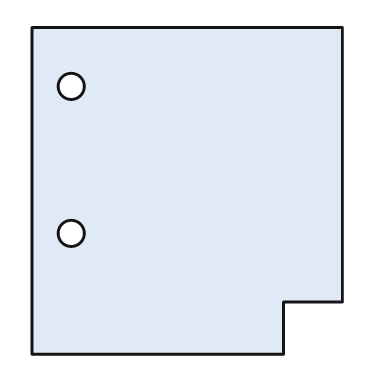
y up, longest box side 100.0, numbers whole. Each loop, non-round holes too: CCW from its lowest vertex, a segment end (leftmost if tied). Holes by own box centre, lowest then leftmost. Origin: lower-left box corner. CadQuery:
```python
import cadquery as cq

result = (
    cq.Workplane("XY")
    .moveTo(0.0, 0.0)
    .lineTo(77.0, 0.0)
    .lineTo(77.0, 16.0)
    .lineTo(95.0, 16.0)
    .lineTo(95.0, 100.0)
    .lineTo(0.0, 100.0)
    .close()
    .moveTo(12.0, 37.0)
    .circle(4.0)
    .moveTo(12.0, 82.0)
    .circle(4.0)
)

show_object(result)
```